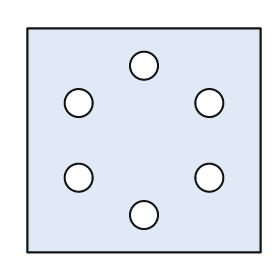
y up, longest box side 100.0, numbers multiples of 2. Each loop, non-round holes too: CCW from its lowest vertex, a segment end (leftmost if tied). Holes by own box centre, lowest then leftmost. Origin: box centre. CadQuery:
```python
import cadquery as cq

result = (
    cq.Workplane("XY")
    .moveTo(-50.0, -48.0)
    .lineTo(50.0, -48.0)
    .lineTo(50.0, 48.0)
    .lineTo(-50.0, 48.0)
    .close()
    .moveTo(0.0, -32.0)
    .circle(6.0)
    .moveTo(-28.0, -16.0)
    .circle(6.0)
    .moveTo(28.0, -16.0)
    .circle(6.0)
    .moveTo(-28.0, 16.0)
    .circle(6.0)
    .moveTo(28.0, 16.0)
    .circle(6.0)
    .moveTo(0.0, 32.0)
    .circle(6.0)
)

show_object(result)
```